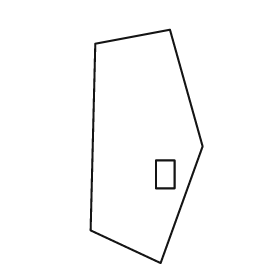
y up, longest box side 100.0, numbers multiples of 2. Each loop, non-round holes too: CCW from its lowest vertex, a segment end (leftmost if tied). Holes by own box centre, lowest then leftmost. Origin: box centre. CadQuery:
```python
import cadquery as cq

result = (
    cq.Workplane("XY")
    .moveTo(6.0, -50.0)
    .lineTo(24.0, 0.0)
    .lineTo(10.0, 50.0)
    .lineTo(-22.0, 44.0)
    .lineTo(-24.0, -36.0)
    .close()
    .moveTo(4.0, -18.0)
    .lineTo(12.0, -18.0)
    .lineTo(12.0, -6.0)
    .lineTo(4.0, -6.0)
    .close()
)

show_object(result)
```